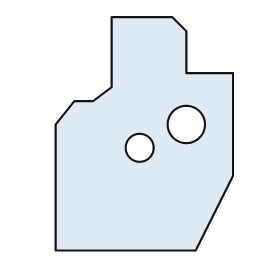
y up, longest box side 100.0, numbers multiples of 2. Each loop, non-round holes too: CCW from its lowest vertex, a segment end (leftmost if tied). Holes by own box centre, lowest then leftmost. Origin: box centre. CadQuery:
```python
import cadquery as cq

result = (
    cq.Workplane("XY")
    .moveTo(-38.0, -50.0)
    .lineTo(22.0, -50.0)
    .lineTo(38.0, -18.0)
    .lineTo(38.0, 26.0)
    .lineTo(18.0, 26.0)
    .lineTo(18.0, 44.0)
    .lineTo(12.0, 50.0)
    .lineTo(-14.0, 50.0)
    .lineTo(-14.0, 20.0)
    .lineTo(-22.0, 14.0)
    .lineTo(-30.0, 14.0)
    .lineTo(-38.0, 4.0)
    .close()
    .moveTo(-2.0, -6.0)
    .circle(6.0)
    .moveTo(18.0, 4.0)
    .circle(8.0)
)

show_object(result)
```